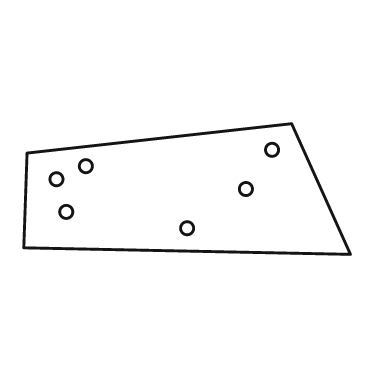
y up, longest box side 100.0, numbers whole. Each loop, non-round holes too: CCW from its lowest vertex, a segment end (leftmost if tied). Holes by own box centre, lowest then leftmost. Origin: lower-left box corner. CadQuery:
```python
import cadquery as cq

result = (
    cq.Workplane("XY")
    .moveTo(100.0, 0.0)
    .lineTo(82.0, 40.0)
    .lineTo(1.0, 31.0)
    .lineTo(0.0, 2.0)
    .close()
    .moveTo(50.0, 8.0)
    .circle(2.0)
    .moveTo(13.0, 13.0)
    .circle(2.0)
    .moveTo(68.0, 20.0)
    .circle(2.0)
    .moveTo(10.0, 23.0)
    .circle(2.0)
    .moveTo(19.0, 27.0)
    .circle(2.0)
    .moveTo(76.0, 32.0)
    .circle(2.0)
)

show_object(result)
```